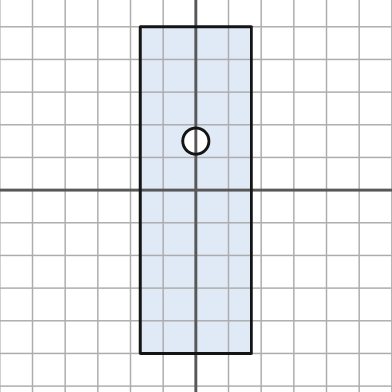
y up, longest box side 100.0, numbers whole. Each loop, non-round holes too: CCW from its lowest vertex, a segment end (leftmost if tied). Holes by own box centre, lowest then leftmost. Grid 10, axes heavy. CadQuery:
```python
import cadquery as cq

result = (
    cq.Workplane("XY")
    .moveTo(-17.0, -50.0)
    .lineTo(17.0, -50.0)
    .lineTo(17.0, 50.0)
    .lineTo(-17.0, 50.0)
    .close()
    .moveTo(0.0, 15.0)
    .circle(4.0)
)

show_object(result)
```